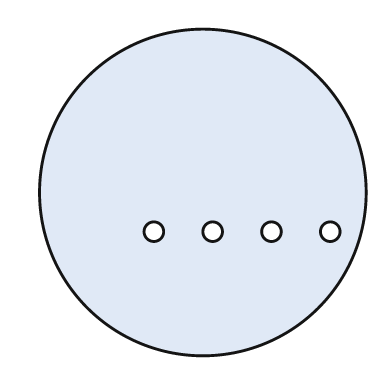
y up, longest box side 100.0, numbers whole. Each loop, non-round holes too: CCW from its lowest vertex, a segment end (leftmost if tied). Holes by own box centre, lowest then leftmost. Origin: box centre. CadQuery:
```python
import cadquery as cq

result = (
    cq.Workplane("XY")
    .moveTo(0.0, 0.0)
    .circle(50.0)
    .moveTo(-15.0, -12.0)
    .circle(3.0)
    .moveTo(3.0, -12.0)
    .circle(3.0)
    .moveTo(21.0, -12.0)
    .circle(3.0)
    .moveTo(39.0, -12.0)
    .circle(3.0)
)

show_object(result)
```